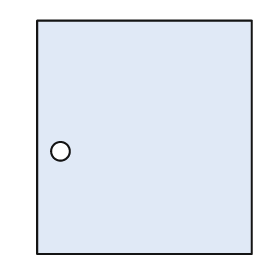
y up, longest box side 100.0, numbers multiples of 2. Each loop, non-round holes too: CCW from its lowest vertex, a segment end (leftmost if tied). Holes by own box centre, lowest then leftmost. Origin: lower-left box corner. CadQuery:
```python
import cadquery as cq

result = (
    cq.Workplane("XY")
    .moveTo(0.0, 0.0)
    .lineTo(92.0, 0.0)
    .lineTo(92.0, 100.0)
    .lineTo(0.0, 100.0)
    .close()
    .moveTo(10.0, 44.0)
    .circle(4.0)
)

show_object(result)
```